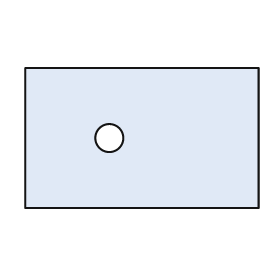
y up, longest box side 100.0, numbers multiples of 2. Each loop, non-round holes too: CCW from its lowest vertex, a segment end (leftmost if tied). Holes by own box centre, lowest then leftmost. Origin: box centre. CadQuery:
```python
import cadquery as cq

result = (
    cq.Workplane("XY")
    .moveTo(-50.0, -30.0)
    .lineTo(50.0, -30.0)
    .lineTo(50.0, 30.0)
    .lineTo(-50.0, 30.0)
    .close()
    .moveTo(-14.0, 0.0)
    .circle(6.0)
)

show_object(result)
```